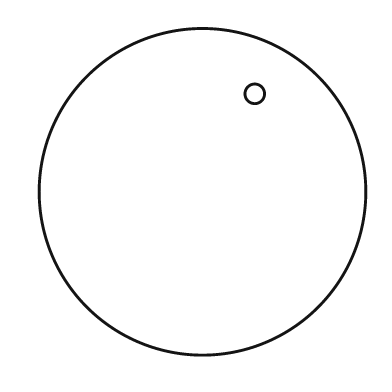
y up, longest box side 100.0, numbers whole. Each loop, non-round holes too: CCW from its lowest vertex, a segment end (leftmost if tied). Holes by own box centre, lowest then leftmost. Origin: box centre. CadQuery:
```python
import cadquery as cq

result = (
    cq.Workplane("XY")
    .moveTo(0.0, 0.0)
    .circle(50.0)
    .moveTo(16.0, 30.0)
    .circle(3.0)
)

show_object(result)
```